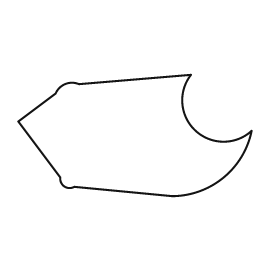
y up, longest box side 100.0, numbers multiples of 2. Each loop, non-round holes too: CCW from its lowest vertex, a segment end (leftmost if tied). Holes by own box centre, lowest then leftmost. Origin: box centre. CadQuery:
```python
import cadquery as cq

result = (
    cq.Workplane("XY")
    .moveTo(16.0, -26.0)
    .threePointArc((38.0, -18.0), (50.0, 2.0))
    .threePointArc((26.0, 2.0), (24.0, 26.0))
    .lineTo(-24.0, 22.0)
    .threePointArc((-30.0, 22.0), (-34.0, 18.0))
    .lineTo(-50.0, 6.0)
    .lineTo(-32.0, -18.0)
    .threePointArc((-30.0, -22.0), (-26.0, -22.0))
    .close()
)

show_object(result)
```